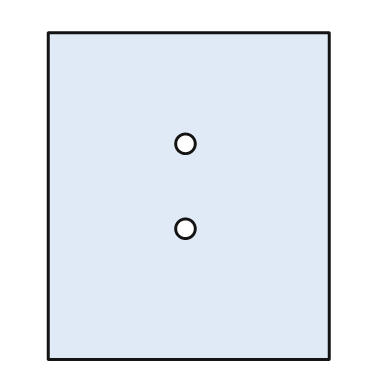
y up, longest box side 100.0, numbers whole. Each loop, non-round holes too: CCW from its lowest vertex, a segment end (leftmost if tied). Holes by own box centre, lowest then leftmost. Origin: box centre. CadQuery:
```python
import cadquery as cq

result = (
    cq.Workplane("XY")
    .moveTo(-43.0, -50.0)
    .lineTo(43.0, -50.0)
    .lineTo(43.0, 50.0)
    .lineTo(-43.0, 50.0)
    .close()
    .moveTo(-1.0, -10.0)
    .circle(3.0)
    .moveTo(-1.0, 16.0)
    .circle(3.0)
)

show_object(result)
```